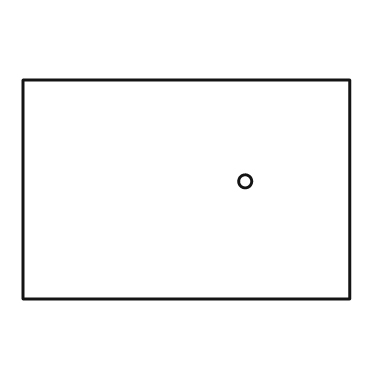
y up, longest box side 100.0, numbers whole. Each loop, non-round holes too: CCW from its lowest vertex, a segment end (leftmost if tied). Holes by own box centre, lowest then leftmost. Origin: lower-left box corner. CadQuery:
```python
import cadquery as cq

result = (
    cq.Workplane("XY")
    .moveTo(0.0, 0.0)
    .lineTo(100.0, 0.0)
    .lineTo(100.0, 67.0)
    .lineTo(0.0, 67.0)
    .close()
    .moveTo(68.0, 36.0)
    .circle(2.0)
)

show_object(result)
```